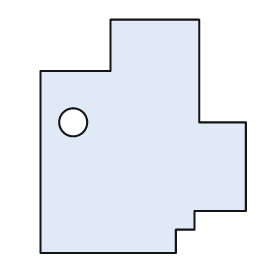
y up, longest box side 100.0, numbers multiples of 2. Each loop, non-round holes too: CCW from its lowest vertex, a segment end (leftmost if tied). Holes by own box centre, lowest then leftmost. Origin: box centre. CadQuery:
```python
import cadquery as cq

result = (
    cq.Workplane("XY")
    .moveTo(-44.0, -50.0)
    .lineTo(14.0, -50.0)
    .lineTo(14.0, -40.0)
    .lineTo(22.0, -40.0)
    .lineTo(22.0, -32.0)
    .lineTo(44.0, -32.0)
    .lineTo(44.0, 6.0)
    .lineTo(24.0, 6.0)
    .lineTo(24.0, 50.0)
    .lineTo(-14.0, 50.0)
    .lineTo(-14.0, 28.0)
    .lineTo(-44.0, 28.0)
    .close()
    .moveTo(-30.0, 6.0)
    .circle(6.0)
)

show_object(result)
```